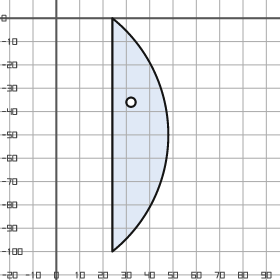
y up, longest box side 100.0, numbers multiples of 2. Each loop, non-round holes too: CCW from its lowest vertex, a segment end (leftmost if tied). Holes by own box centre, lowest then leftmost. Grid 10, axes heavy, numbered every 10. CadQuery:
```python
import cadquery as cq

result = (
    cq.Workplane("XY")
    .moveTo(24.0, -100.0)
    .threePointArc((48.0, -50.0), (24.0, 0.0))
    .close()
    .moveTo(32.0, -36.0)
    .circle(2.0)
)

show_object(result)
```